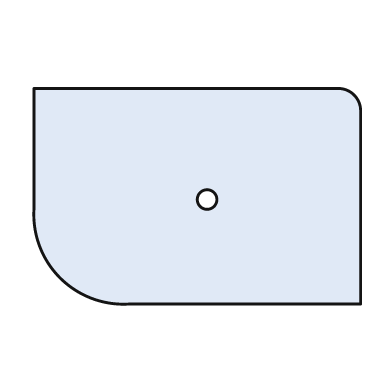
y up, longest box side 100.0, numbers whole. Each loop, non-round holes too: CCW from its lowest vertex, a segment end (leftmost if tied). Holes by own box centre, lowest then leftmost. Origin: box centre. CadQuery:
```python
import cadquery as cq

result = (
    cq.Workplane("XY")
    .moveTo(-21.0, -33.0)
    .lineTo(50.0, -33.0)
    .lineTo(50.0, 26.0)
    .threePointArc((48.0, 31.0), (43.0, 33.0))
    .lineTo(-50.0, 33.0)
    .lineTo(-50.0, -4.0)
    .threePointArc((-42.0, -25.0), (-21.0, -33.0))
    .close()
    .moveTo(3.0, -1.0)
    .circle(3.0)
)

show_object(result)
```